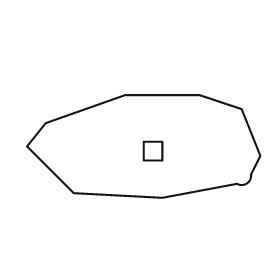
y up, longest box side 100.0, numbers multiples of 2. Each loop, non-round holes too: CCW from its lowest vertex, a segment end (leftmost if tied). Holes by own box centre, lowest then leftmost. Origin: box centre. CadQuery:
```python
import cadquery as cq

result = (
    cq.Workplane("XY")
    .moveTo(8.0, -22.0)
    .lineTo(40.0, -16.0)
    .threePointArc((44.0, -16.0), (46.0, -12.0))
    .lineTo(50.0, -4.0)
    .lineTo(42.0, 16.0)
    .lineTo(24.0, 22.0)
    .lineTo(-8.0, 22.0)
    .lineTo(-42.0, 10.0)
    .lineTo(-50.0, 0.0)
    .lineTo(-30.0, -20.0)
    .close()
    .moveTo(0.0, -6.0)
    .lineTo(8.0, -6.0)
    .lineTo(8.0, 2.0)
    .lineTo(0.0, 2.0)
    .close()
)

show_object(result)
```